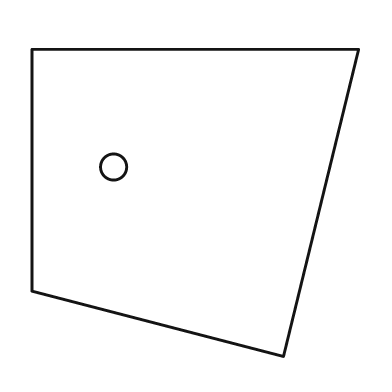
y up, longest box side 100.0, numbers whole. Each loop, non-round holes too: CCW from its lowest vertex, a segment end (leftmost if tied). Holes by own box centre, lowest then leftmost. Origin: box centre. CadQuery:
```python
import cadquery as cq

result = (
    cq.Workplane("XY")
    .moveTo(27.0, -47.0)
    .lineTo(50.0, 47.0)
    .lineTo(-50.0, 47.0)
    .lineTo(-50.0, -27.0)
    .close()
    .moveTo(-25.0, 11.0)
    .circle(4.0)
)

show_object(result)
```